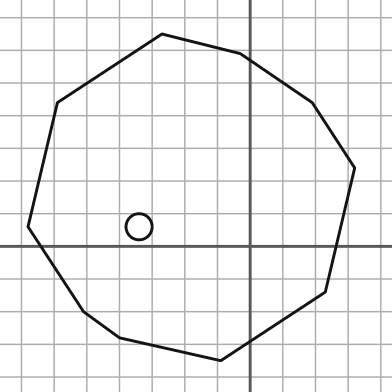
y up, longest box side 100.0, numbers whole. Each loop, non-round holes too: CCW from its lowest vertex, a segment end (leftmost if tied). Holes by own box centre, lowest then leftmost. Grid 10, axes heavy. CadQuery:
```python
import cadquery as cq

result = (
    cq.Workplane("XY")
    .moveTo(-9.0, -35.0)
    .lineTo(23.0, -14.0)
    .lineTo(32.0, 24.0)
    .lineTo(19.0, 44.0)
    .lineTo(-3.0, 59.0)
    .lineTo(-27.0, 65.0)
    .lineTo(-59.0, 44.0)
    .lineTo(-68.0, 6.0)
    .lineTo(-51.0, -20.0)
    .lineTo(-40.0, -28.0)
    .close()
    .moveTo(-34.0, 6.0)
    .circle(4.0)
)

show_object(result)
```